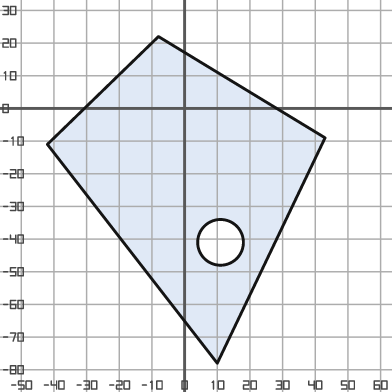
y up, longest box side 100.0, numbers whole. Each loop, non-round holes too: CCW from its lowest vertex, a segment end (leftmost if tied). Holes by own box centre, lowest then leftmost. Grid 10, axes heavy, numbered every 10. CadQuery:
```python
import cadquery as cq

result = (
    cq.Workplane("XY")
    .moveTo(10.0, -78.0)
    .lineTo(43.0, -9.0)
    .lineTo(-8.0, 22.0)
    .lineTo(-42.0, -11.0)
    .close()
    .moveTo(11.0, -41.0)
    .circle(7.0)
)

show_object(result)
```